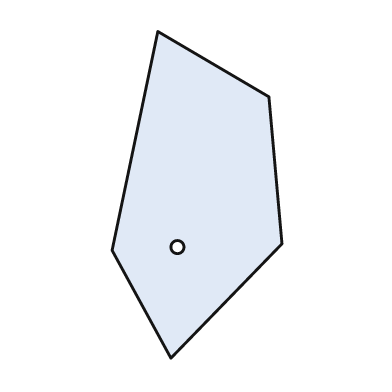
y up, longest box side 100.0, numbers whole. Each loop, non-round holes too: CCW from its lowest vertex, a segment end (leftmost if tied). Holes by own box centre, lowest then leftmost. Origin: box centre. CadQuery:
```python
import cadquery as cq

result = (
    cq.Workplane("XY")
    .moveTo(-8.0, -50.0)
    .lineTo(26.0, -15.0)
    .lineTo(22.0, 30.0)
    .lineTo(-12.0, 50.0)
    .lineTo(-26.0, -17.0)
    .close()
    .moveTo(-6.0, -16.0)
    .circle(2.0)
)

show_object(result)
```